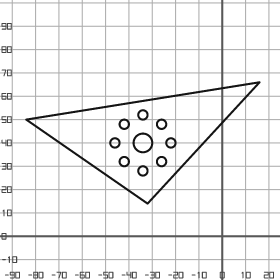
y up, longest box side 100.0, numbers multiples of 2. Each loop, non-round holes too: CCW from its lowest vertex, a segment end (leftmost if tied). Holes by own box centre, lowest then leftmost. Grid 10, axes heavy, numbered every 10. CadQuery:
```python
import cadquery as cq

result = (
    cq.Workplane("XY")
    .moveTo(-32.0, 14.0)
    .lineTo(16.0, 66.0)
    .lineTo(-84.0, 50.0)
    .close()
    .moveTo(-34.0, 28.0)
    .circle(2.0)
    .moveTo(-42.0, 32.0)
    .circle(2.0)
    .moveTo(-26.0, 32.0)
    .circle(2.0)
    .moveTo(-46.0, 40.0)
    .circle(2.0)
    .moveTo(-34.0, 40.0)
    .circle(4.0)
    .moveTo(-22.0, 40.0)
    .circle(2.0)
    .moveTo(-42.0, 48.0)
    .circle(2.0)
    .moveTo(-26.0, 48.0)
    .circle(2.0)
    .moveTo(-34.0, 52.0)
    .circle(2.0)
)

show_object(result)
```